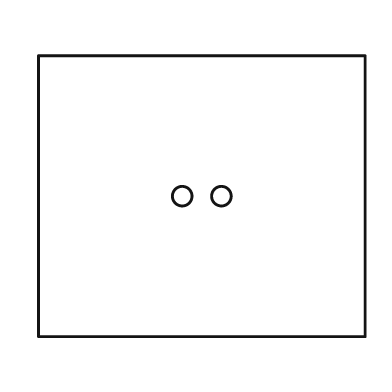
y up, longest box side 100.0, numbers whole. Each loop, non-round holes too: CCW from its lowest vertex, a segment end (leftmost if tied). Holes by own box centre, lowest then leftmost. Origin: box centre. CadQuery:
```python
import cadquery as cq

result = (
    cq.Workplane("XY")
    .moveTo(-50.0, -43.0)
    .lineTo(50.0, -43.0)
    .lineTo(50.0, 43.0)
    .lineTo(-50.0, 43.0)
    .close()
    .moveTo(-6.0, 0.0)
    .circle(3.0)
    .moveTo(6.0, 0.0)
    .circle(3.0)
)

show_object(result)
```